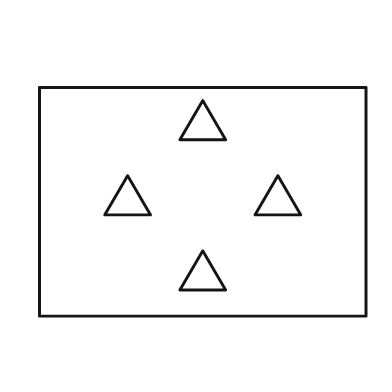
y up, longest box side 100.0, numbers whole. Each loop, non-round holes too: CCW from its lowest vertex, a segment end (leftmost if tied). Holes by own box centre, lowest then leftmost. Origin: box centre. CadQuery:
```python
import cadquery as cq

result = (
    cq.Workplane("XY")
    .moveTo(-50.0, -35.0)
    .lineTo(50.0, -35.0)
    .lineTo(50.0, 35.0)
    .lineTo(-50.0, 35.0)
    .close()
    .moveTo(-7.0, -27.0)
    .lineTo(7.0, -27.0)
    .lineTo(0.0, -15.0)
    .close()
    .moveTo(-30.0, -4.0)
    .lineTo(-16.0, -4.0)
    .lineTo(-23.0, 8.0)
    .close()
    .moveTo(16.0, -4.0)
    .lineTo(30.0, -4.0)
    .lineTo(23.0, 8.0)
    .close()
    .moveTo(-7.0, 19.0)
    .lineTo(7.0, 19.0)
    .lineTo(0.0, 31.0)
    .close()
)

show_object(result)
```